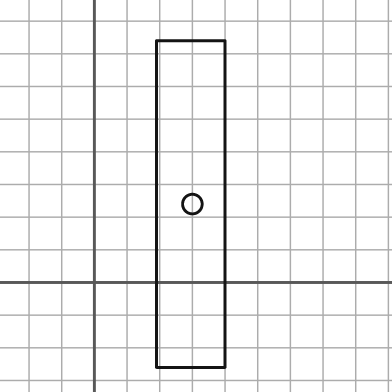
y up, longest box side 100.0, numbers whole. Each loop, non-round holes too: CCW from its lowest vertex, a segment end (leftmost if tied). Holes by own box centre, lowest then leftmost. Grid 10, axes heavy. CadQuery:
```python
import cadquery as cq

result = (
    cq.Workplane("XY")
    .moveTo(19.0, -26.0)
    .lineTo(40.0, -26.0)
    .lineTo(40.0, 74.0)
    .lineTo(19.0, 74.0)
    .close()
    .moveTo(30.0, 24.0)
    .circle(3.0)
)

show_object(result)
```